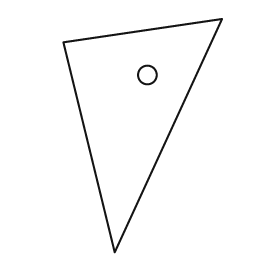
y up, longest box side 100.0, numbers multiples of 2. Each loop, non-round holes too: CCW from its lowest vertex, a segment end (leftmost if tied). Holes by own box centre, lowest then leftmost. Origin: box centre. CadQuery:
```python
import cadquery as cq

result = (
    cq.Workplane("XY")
    .moveTo(-12.0, -50.0)
    .lineTo(34.0, 50.0)
    .lineTo(-34.0, 40.0)
    .close()
    .moveTo(2.0, 26.0)
    .circle(4.0)
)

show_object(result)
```